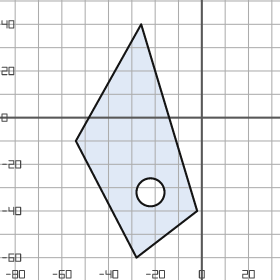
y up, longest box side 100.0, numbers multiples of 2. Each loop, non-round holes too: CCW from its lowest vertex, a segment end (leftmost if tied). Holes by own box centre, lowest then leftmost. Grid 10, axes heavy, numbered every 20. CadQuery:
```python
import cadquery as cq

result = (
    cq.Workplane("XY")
    .moveTo(-28.0, -60.0)
    .lineTo(-2.0, -40.0)
    .lineTo(-26.0, 40.0)
    .lineTo(-54.0, -10.0)
    .close()
    .moveTo(-22.0, -32.0)
    .circle(6.0)
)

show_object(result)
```